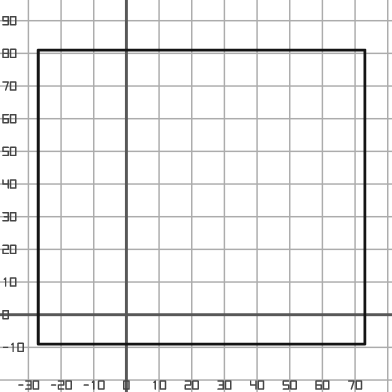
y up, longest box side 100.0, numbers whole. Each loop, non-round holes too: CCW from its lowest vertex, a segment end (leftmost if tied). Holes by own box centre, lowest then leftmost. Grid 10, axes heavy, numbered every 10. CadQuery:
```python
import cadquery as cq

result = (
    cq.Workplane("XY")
    .moveTo(-27.0, -9.0)
    .lineTo(73.0, -9.0)
    .lineTo(73.0, 81.0)
    .lineTo(-27.0, 81.0)
    .close()
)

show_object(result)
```